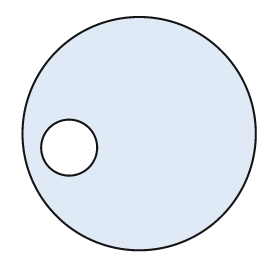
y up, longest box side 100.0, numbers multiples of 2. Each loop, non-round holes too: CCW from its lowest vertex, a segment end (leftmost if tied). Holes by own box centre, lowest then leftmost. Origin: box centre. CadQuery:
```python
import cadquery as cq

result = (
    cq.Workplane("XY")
    .moveTo(0.0, 0.0)
    .circle(50.0)
    .moveTo(-30.0, -6.0)
    .circle(12.0)
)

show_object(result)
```